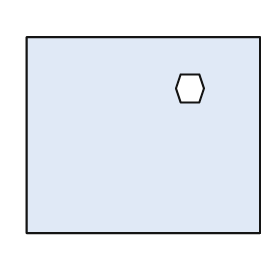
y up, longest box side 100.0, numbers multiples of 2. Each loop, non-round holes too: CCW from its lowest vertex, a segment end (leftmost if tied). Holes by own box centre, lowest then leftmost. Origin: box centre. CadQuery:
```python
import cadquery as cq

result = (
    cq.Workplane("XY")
    .moveTo(-50.0, -42.0)
    .lineTo(50.0, -42.0)
    .lineTo(50.0, 42.0)
    .lineTo(-50.0, 42.0)
    .close()
    .moveTo(16.0, 14.0)
    .lineTo(24.0, 14.0)
    .lineTo(26.0, 20.0)
    .lineTo(24.0, 26.0)
    .lineTo(16.0, 26.0)
    .lineTo(14.0, 20.0)
    .close()
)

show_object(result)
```